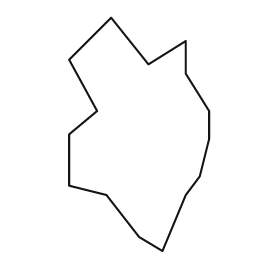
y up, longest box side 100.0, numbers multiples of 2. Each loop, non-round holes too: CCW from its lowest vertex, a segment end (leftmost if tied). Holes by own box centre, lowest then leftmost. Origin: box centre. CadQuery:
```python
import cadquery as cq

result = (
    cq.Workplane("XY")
    .moveTo(10.0, -50.0)
    .lineTo(20.0, -26.0)
    .lineTo(26.0, -18.0)
    .lineTo(30.0, -2.0)
    .lineTo(30.0, 10.0)
    .lineTo(20.0, 26.0)
    .lineTo(20.0, 40.0)
    .lineTo(4.0, 30.0)
    .lineTo(-12.0, 50.0)
    .lineTo(-30.0, 32.0)
    .lineTo(-18.0, 10.0)
    .lineTo(-30.0, 0.0)
    .lineTo(-30.0, -22.0)
    .lineTo(-14.0, -26.0)
    .lineTo(0.0, -44.0)
    .close()
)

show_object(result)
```